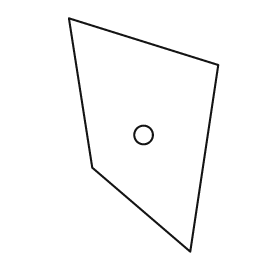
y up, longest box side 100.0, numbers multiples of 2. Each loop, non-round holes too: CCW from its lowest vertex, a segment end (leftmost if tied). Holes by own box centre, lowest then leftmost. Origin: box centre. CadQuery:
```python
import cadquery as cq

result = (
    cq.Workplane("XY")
    .moveTo(20.0, -50.0)
    .lineTo(32.0, 30.0)
    .lineTo(-32.0, 50.0)
    .lineTo(-22.0, -14.0)
    .close()
    .moveTo(0.0, 0.0)
    .circle(4.0)
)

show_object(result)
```